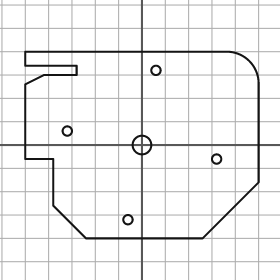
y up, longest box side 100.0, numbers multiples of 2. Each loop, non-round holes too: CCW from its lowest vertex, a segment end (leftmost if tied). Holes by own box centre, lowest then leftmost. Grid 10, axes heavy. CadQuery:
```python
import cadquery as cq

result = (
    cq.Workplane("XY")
    .moveTo(-24.0, -40.0)
    .lineTo(26.0, -40.0)
    .lineTo(50.0, -16.0)
    .lineTo(50.0, 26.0)
    .threePointArc((46.0, 36.0), (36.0, 40.0))
    .lineTo(-50.0, 40.0)
    .lineTo(-50.0, 34.0)
    .lineTo(-28.0, 34.0)
    .lineTo(-28.0, 30.0)
    .lineTo(-42.0, 30.0)
    .lineTo(-50.0, 26.0)
    .lineTo(-50.0, -6.0)
    .lineTo(-38.0, -6.0)
    .lineTo(-38.0, -26.0)
    .close()
    .moveTo(-6.0, -32.0)
    .circle(2.0)
    .moveTo(32.0, -6.0)
    .circle(2.0)
    .moveTo(0.0, 0.0)
    .circle(4.0)
    .moveTo(-32.0, 6.0)
    .circle(2.0)
    .moveTo(6.0, 32.0)
    .circle(2.0)
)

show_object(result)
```